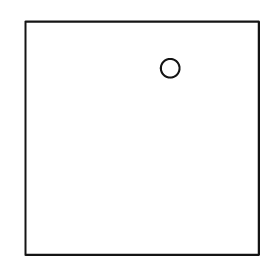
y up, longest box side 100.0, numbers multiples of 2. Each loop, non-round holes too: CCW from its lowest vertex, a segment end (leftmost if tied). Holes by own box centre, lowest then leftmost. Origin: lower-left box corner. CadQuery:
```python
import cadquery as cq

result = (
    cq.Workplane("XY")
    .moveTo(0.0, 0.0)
    .lineTo(100.0, 0.0)
    .lineTo(100.0, 100.0)
    .lineTo(0.0, 100.0)
    .close()
    .moveTo(62.0, 80.0)
    .circle(4.0)
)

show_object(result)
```